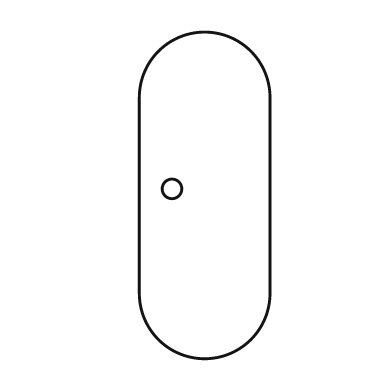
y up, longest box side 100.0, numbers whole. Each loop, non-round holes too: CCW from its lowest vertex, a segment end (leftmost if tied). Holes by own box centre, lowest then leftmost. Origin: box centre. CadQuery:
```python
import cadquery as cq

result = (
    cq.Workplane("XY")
    .moveTo(-20.0, -30.0)
    .threePointArc((0.0, -50.0), (20.0, -30.0))
    .lineTo(20.0, 30.0)
    .threePointArc((0.0, 50.0), (-20.0, 30.0))
    .close()
    .moveTo(-10.0, 2.0)
    .circle(3.0)
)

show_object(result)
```